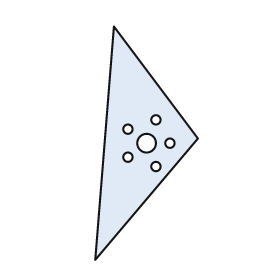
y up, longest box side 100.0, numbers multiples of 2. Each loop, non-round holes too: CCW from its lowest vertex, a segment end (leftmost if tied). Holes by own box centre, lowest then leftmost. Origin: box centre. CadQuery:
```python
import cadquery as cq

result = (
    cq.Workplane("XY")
    .moveTo(-22.0, -50.0)
    .lineTo(22.0, 2.0)
    .lineTo(-14.0, 50.0)
    .close()
    .moveTo(4.0, -10.0)
    .circle(2.0)
    .moveTo(-8.0, -6.0)
    .circle(2.0)
    .moveTo(0.0, 0.0)
    .circle(4.0)
    .moveTo(10.0, 0.0)
    .circle(2.0)
    .moveTo(-8.0, 6.0)
    .circle(2.0)
    .moveTo(4.0, 10.0)
    .circle(2.0)
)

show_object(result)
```